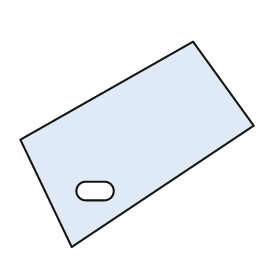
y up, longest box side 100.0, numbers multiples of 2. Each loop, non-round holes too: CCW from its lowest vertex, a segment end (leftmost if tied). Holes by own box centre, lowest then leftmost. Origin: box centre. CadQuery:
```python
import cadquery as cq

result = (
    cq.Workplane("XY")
    .moveTo(-28.0, -44.0)
    .lineTo(50.0, 8.0)
    .lineTo(24.0, 44.0)
    .lineTo(-50.0, 2.0)
    .close()
    .moveTo(-22.0, -24.0)
    .lineTo(-14.0, -24.0)
    .threePointArc((-10.0, -20.0), (-14.0, -16.0))
    .lineTo(-22.0, -16.0)
    .threePointArc((-26.0, -20.0), (-22.0, -24.0))
    .close()
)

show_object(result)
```